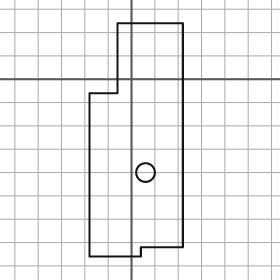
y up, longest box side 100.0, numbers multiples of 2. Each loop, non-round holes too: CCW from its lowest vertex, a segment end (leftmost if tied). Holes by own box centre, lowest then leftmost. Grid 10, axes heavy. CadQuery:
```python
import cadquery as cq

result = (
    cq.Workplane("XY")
    .moveTo(-18.0, -76.0)
    .lineTo(4.0, -76.0)
    .lineTo(4.0, -72.0)
    .lineTo(22.0, -72.0)
    .lineTo(22.0, 24.0)
    .lineTo(-6.0, 24.0)
    .lineTo(-6.0, -6.0)
    .lineTo(-18.0, -6.0)
    .close()
    .moveTo(6.0, -40.0)
    .circle(4.0)
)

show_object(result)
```